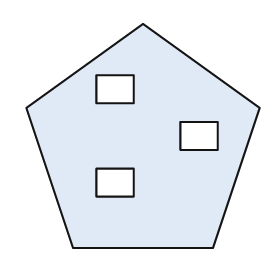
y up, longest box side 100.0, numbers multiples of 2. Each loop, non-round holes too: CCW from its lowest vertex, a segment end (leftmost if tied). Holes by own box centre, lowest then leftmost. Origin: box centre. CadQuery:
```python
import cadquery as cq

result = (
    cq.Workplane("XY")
    .moveTo(-30.0, -48.0)
    .lineTo(30.0, -48.0)
    .lineTo(50.0, 12.0)
    .lineTo(0.0, 48.0)
    .lineTo(-50.0, 12.0)
    .close()
    .moveTo(-20.0, -26.0)
    .lineTo(-4.0, -26.0)
    .lineTo(-4.0, -14.0)
    .lineTo(-20.0, -14.0)
    .close()
    .moveTo(16.0, -6.0)
    .lineTo(32.0, -6.0)
    .lineTo(32.0, 6.0)
    .lineTo(16.0, 6.0)
    .close()
    .moveTo(-20.0, 14.0)
    .lineTo(-4.0, 14.0)
    .lineTo(-4.0, 26.0)
    .lineTo(-20.0, 26.0)
    .close()
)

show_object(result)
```